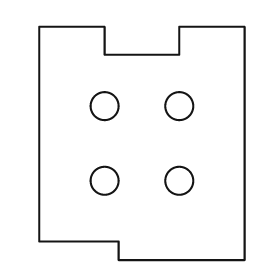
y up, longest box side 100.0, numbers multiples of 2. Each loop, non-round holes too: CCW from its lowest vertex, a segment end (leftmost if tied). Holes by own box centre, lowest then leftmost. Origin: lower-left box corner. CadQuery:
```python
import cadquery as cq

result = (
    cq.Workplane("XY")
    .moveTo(34.0, 0.0)
    .lineTo(88.0, 0.0)
    .lineTo(88.0, 100.0)
    .lineTo(60.0, 100.0)
    .lineTo(60.0, 88.0)
    .lineTo(28.0, 88.0)
    .lineTo(28.0, 100.0)
    .lineTo(0.0, 100.0)
    .lineTo(0.0, 8.0)
    .lineTo(34.0, 8.0)
    .close()
    .moveTo(28.0, 34.0)
    .circle(6.0)
    .moveTo(60.0, 34.0)
    .circle(6.0)
    .moveTo(28.0, 66.0)
    .circle(6.0)
    .moveTo(60.0, 66.0)
    .circle(6.0)
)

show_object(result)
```